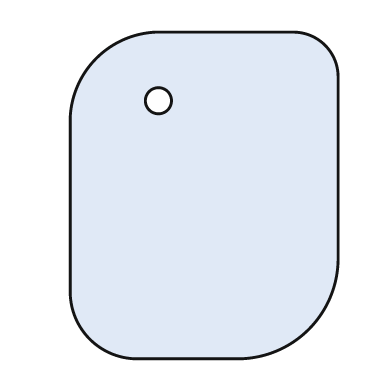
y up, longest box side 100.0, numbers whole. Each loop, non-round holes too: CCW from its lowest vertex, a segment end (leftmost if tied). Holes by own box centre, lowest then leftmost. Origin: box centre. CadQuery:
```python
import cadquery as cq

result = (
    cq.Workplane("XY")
    .moveTo(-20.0, -50.0)
    .lineTo(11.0, -50.0)
    .threePointArc((32.0, -41.0), (41.0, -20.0))
    .lineTo(41.0, 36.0)
    .threePointArc((37.0, 46.0), (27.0, 50.0))
    .lineTo(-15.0, 50.0)
    .threePointArc((-33.0, 42.0), (-41.0, 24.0))
    .lineTo(-41.0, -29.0)
    .threePointArc((-35.0, -44.0), (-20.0, -50.0))
    .close()
    .moveTo(-14.0, 29.0)
    .circle(4.0)
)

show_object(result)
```